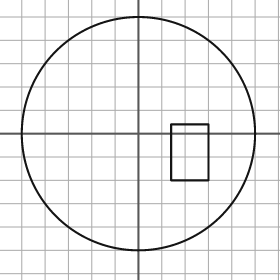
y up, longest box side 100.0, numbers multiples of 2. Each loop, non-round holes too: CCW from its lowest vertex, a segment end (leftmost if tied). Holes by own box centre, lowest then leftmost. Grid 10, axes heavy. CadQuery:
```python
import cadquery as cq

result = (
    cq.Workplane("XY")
    .moveTo(0.0, 0.0)
    .circle(50.0)
    .moveTo(14.0, -20.0)
    .lineTo(30.0, -20.0)
    .lineTo(30.0, 4.0)
    .lineTo(14.0, 4.0)
    .close()
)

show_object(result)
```